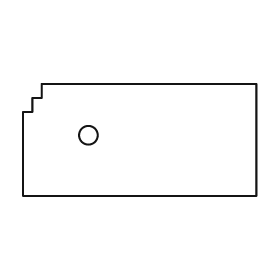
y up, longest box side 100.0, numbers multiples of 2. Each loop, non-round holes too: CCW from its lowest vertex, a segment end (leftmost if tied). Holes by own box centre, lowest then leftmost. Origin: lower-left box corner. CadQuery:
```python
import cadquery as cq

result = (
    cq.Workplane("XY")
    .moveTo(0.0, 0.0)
    .lineTo(100.0, 0.0)
    .lineTo(100.0, 48.0)
    .lineTo(8.0, 48.0)
    .lineTo(8.0, 42.0)
    .lineTo(4.0, 42.0)
    .lineTo(4.0, 36.0)
    .lineTo(0.0, 36.0)
    .close()
    .moveTo(28.0, 26.0)
    .circle(4.0)
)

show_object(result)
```